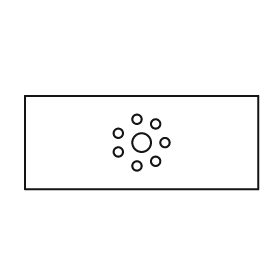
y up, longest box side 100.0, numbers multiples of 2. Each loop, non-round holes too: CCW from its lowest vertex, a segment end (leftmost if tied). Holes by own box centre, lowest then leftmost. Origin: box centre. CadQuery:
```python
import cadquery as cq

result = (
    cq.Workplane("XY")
    .moveTo(-50.0, -20.0)
    .lineTo(50.0, -20.0)
    .lineTo(50.0, 20.0)
    .lineTo(-50.0, 20.0)
    .close()
    .moveTo(-2.0, -10.0)
    .circle(2.0)
    .moveTo(6.0, -8.0)
    .circle(2.0)
    .moveTo(-10.0, -4.0)
    .circle(2.0)
    .moveTo(0.0, 0.0)
    .circle(4.0)
    .moveTo(10.0, 0.0)
    .circle(2.0)
    .moveTo(-10.0, 4.0)
    .circle(2.0)
    .moveTo(6.0, 8.0)
    .circle(2.0)
    .moveTo(-2.0, 10.0)
    .circle(2.0)
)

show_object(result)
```